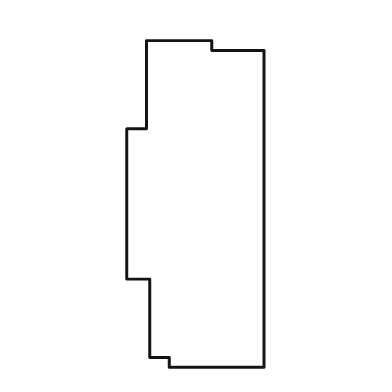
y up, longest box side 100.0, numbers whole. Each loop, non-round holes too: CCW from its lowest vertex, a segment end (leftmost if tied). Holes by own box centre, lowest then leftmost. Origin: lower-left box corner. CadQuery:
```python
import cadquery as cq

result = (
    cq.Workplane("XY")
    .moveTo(13.0, 0.0)
    .lineTo(42.0, 0.0)
    .lineTo(42.0, 97.0)
    .lineTo(26.0, 97.0)
    .lineTo(26.0, 100.0)
    .lineTo(6.0, 100.0)
    .lineTo(6.0, 73.0)
    .lineTo(0.0, 73.0)
    .lineTo(0.0, 27.0)
    .lineTo(7.0, 27.0)
    .lineTo(7.0, 3.0)
    .lineTo(13.0, 3.0)
    .close()
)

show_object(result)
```